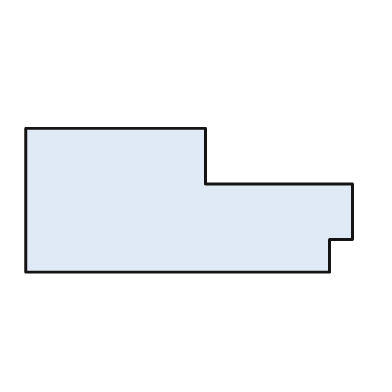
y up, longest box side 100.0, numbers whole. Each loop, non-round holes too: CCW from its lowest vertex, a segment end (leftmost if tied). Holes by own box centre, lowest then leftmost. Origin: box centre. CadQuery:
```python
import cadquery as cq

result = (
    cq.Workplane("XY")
    .moveTo(-50.0, -22.0)
    .lineTo(43.0, -22.0)
    .lineTo(43.0, -12.0)
    .lineTo(50.0, -12.0)
    .lineTo(50.0, 5.0)
    .lineTo(5.0, 5.0)
    .lineTo(5.0, 22.0)
    .lineTo(-50.0, 22.0)
    .close()
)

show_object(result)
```